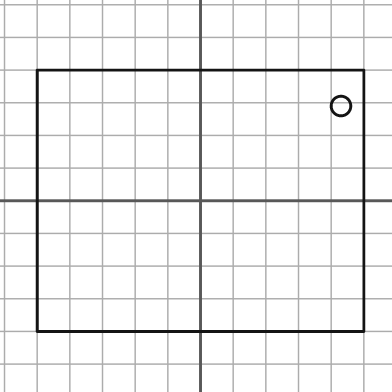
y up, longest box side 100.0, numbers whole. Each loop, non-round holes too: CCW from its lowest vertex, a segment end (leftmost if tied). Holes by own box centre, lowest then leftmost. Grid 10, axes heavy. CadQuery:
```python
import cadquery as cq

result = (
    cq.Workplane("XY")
    .moveTo(-50.0, -40.0)
    .lineTo(50.0, -40.0)
    .lineTo(50.0, 40.0)
    .lineTo(-50.0, 40.0)
    .close()
    .moveTo(43.0, 29.0)
    .circle(3.0)
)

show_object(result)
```